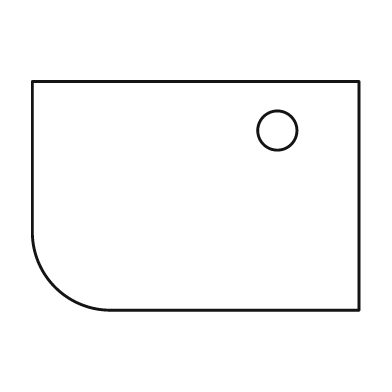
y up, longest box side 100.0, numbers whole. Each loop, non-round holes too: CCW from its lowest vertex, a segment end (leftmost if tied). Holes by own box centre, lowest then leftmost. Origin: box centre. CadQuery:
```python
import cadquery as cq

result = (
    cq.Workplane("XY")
    .moveTo(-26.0, -35.0)
    .lineTo(50.0, -35.0)
    .lineTo(50.0, 35.0)
    .lineTo(-50.0, 35.0)
    .lineTo(-50.0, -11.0)
    .threePointArc((-43.0, -28.0), (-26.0, -35.0))
    .close()
    .moveTo(25.0, 20.0)
    .circle(6.0)
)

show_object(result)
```